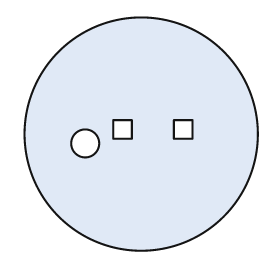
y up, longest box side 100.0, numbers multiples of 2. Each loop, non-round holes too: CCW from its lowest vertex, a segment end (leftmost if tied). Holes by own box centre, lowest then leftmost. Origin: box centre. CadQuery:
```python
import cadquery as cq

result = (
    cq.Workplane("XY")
    .moveTo(0.0, 0.0)
    .circle(50.0)
    .moveTo(-24.0, -4.0)
    .circle(6.0)
    .moveTo(-12.0, -2.0)
    .lineTo(-4.0, -2.0)
    .lineTo(-4.0, 6.0)
    .lineTo(-12.0, 6.0)
    .close()
    .moveTo(14.0, -2.0)
    .lineTo(22.0, -2.0)
    .lineTo(22.0, 6.0)
    .lineTo(14.0, 6.0)
    .close()
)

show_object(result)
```